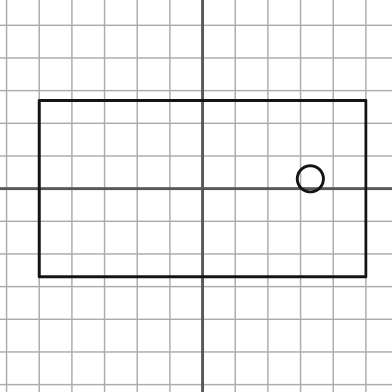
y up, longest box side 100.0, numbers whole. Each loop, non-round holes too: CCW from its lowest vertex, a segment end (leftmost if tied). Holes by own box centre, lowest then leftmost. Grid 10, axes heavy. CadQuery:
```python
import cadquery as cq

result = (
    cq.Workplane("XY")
    .moveTo(-50.0, -27.0)
    .lineTo(50.0, -27.0)
    .lineTo(50.0, 27.0)
    .lineTo(-50.0, 27.0)
    .close()
    .moveTo(33.0, 3.0)
    .circle(4.0)
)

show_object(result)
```